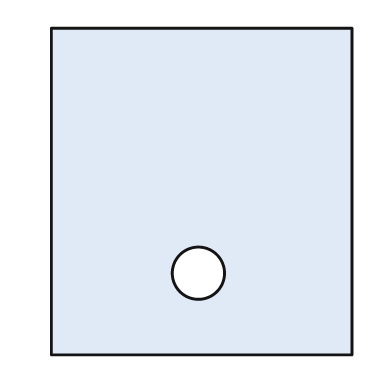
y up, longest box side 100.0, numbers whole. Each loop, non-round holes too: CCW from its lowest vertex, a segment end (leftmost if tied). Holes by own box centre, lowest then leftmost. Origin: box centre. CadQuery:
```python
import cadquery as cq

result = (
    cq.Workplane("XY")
    .moveTo(-46.0, -50.0)
    .lineTo(46.0, -50.0)
    .lineTo(46.0, 50.0)
    .lineTo(-46.0, 50.0)
    .close()
    .moveTo(-1.0, -25.0)
    .circle(8.0)
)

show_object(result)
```